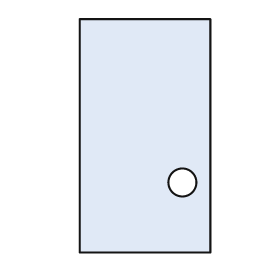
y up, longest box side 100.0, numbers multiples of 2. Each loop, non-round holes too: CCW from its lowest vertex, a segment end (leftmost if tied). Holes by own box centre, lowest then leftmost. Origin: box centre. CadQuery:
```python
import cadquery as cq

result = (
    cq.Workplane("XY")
    .moveTo(-28.0, -50.0)
    .lineTo(28.0, -50.0)
    .lineTo(28.0, 50.0)
    .lineTo(-28.0, 50.0)
    .close()
    .moveTo(16.0, -20.0)
    .circle(6.0)
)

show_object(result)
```